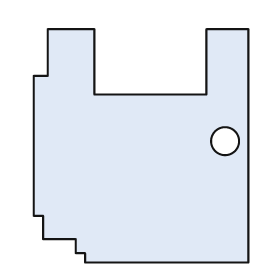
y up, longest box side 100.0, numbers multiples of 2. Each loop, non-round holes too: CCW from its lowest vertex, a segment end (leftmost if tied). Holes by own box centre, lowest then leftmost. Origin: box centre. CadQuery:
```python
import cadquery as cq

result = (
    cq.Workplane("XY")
    .moveTo(-24.0, -50.0)
    .lineTo(46.0, -50.0)
    .lineTo(46.0, 50.0)
    .lineTo(28.0, 50.0)
    .lineTo(28.0, 22.0)
    .lineTo(-20.0, 22.0)
    .lineTo(-20.0, 50.0)
    .lineTo(-40.0, 50.0)
    .lineTo(-40.0, 30.0)
    .lineTo(-46.0, 30.0)
    .lineTo(-46.0, -30.0)
    .lineTo(-42.0, -30.0)
    .lineTo(-42.0, -40.0)
    .lineTo(-28.0, -40.0)
    .lineTo(-28.0, -46.0)
    .lineTo(-24.0, -46.0)
    .close()
    .moveTo(36.0, 2.0)
    .circle(6.0)
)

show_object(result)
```